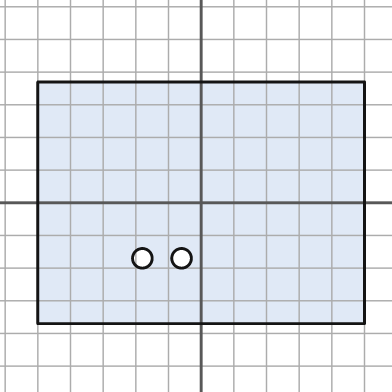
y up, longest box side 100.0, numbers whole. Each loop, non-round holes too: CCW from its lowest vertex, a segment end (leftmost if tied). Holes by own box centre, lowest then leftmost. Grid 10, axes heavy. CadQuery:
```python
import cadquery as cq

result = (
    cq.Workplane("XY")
    .moveTo(-50.0, -37.0)
    .lineTo(50.0, -37.0)
    .lineTo(50.0, 37.0)
    .lineTo(-50.0, 37.0)
    .close()
    .moveTo(-18.0, -17.0)
    .circle(3.0)
    .moveTo(-6.0, -17.0)
    .circle(3.0)
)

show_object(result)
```